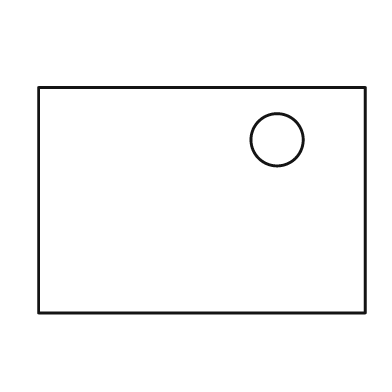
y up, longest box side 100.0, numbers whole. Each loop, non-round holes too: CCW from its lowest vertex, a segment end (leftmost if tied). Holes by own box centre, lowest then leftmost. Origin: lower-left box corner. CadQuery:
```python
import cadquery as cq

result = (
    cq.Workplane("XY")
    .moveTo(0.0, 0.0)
    .lineTo(100.0, 0.0)
    .lineTo(100.0, 69.0)
    .lineTo(0.0, 69.0)
    .close()
    .moveTo(73.0, 53.0)
    .circle(8.0)
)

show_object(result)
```